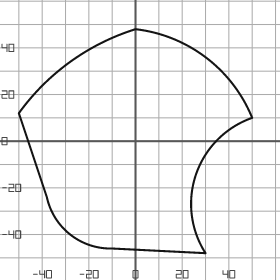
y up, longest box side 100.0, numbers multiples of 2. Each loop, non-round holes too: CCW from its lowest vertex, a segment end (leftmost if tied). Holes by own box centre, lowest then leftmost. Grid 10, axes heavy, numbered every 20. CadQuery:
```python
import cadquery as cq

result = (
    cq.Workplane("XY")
    .moveTo(30.0, -48.0)
    .threePointArc((26.0, -14.0), (50.0, 10.0))
    .threePointArc((30.0, 36.0), (0.0, 48.0))
    .threePointArc((-28.0, 34.0), (-50.0, 12.0))
    .lineTo(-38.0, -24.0)
    .threePointArc((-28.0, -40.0), (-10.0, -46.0))
    .close()
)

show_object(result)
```